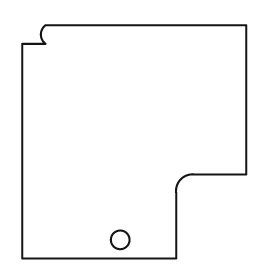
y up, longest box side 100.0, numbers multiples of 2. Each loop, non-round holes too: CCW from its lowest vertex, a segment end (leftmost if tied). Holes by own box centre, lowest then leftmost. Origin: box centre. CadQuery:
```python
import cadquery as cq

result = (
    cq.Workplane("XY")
    .moveTo(-48.0, -50.0)
    .lineTo(18.0, -50.0)
    .lineTo(18.0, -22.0)
    .threePointArc((20.0, -16.0), (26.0, -14.0))
    .lineTo(48.0, -14.0)
    .lineTo(48.0, 50.0)
    .lineTo(-38.0, 50.0)
    .threePointArc((-40.0, 46.0), (-38.0, 42.0))
    .lineTo(-48.0, 42.0)
    .close()
    .moveTo(-6.0, -42.0)
    .circle(4.0)
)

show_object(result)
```